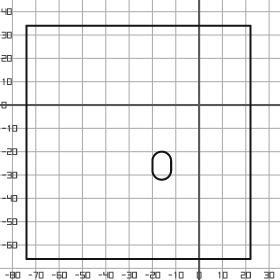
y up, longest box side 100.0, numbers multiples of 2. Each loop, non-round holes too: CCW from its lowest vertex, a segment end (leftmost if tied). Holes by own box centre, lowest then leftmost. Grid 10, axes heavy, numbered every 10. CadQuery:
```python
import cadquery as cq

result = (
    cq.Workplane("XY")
    .moveTo(-74.0, -66.0)
    .lineTo(22.0, -66.0)
    .lineTo(22.0, 34.0)
    .lineTo(-74.0, 34.0)
    .close()
    .moveTo(-20.0, -28.0)
    .threePointArc((-16.0, -32.0), (-12.0, -28.0))
    .lineTo(-12.0, -24.0)
    .threePointArc((-16.0, -20.0), (-20.0, -24.0))
    .close()
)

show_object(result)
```